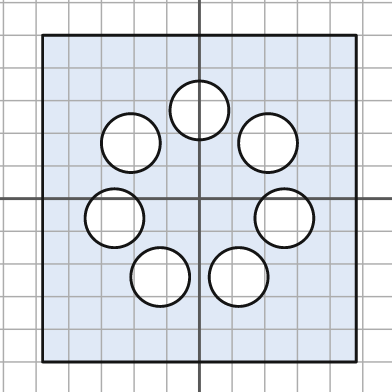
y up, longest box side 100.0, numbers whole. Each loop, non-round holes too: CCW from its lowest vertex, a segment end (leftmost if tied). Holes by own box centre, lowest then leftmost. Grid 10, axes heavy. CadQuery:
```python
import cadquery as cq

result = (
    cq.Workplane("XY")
    .moveTo(-48.0, -50.0)
    .lineTo(48.0, -50.0)
    .lineTo(48.0, 50.0)
    .lineTo(-48.0, 50.0)
    .close()
    .moveTo(-12.0, -24.0)
    .circle(9.0)
    .moveTo(12.0, -24.0)
    .circle(9.0)
    .moveTo(-26.0, -6.0)
    .circle(9.0)
    .moveTo(26.0, -6.0)
    .circle(9.0)
    .moveTo(-21.0, 17.0)
    .circle(9.0)
    .moveTo(21.0, 17.0)
    .circle(9.0)
    .moveTo(0.0, 27.0)
    .circle(9.0)
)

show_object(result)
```